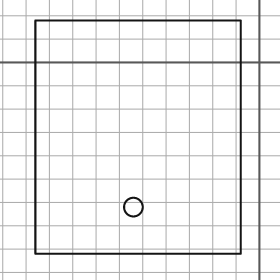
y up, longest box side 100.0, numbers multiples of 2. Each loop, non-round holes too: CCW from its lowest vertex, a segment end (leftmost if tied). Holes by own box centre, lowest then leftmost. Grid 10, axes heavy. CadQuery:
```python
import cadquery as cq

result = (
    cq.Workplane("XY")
    .moveTo(-96.0, -82.0)
    .lineTo(-8.0, -82.0)
    .lineTo(-8.0, 18.0)
    .lineTo(-96.0, 18.0)
    .close()
    .moveTo(-54.0, -62.0)
    .circle(4.0)
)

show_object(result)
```